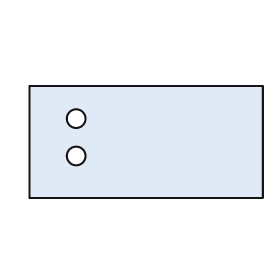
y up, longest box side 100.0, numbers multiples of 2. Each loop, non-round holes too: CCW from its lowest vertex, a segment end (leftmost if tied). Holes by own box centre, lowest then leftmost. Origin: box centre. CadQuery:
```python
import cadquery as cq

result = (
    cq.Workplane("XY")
    .moveTo(-50.0, -24.0)
    .lineTo(50.0, -24.0)
    .lineTo(50.0, 24.0)
    .lineTo(-50.0, 24.0)
    .close()
    .moveTo(-30.0, -6.0)
    .circle(4.0)
    .moveTo(-30.0, 10.0)
    .circle(4.0)
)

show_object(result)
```